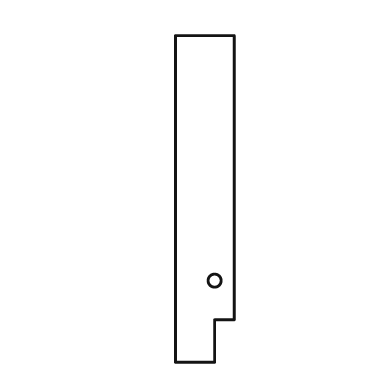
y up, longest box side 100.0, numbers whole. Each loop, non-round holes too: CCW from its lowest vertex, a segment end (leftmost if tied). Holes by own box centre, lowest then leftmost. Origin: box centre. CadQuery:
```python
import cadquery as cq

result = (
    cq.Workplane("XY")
    .moveTo(-9.0, -50.0)
    .lineTo(3.0, -50.0)
    .lineTo(3.0, -37.0)
    .lineTo(9.0, -37.0)
    .lineTo(9.0, 50.0)
    .lineTo(-9.0, 50.0)
    .close()
    .moveTo(3.0, -25.0)
    .circle(2.0)
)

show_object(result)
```